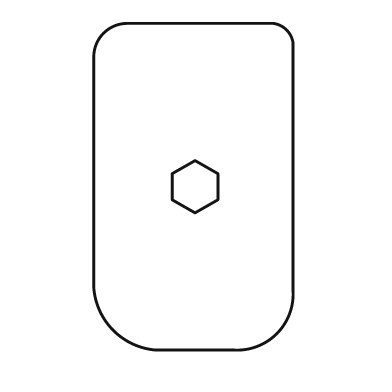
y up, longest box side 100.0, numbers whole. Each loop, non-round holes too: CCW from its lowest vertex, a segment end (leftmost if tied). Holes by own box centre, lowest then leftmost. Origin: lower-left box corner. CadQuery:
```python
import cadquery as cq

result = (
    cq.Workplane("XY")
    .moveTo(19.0, 0.0)
    .lineTo(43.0, 0.0)
    .threePointArc((56.0, 5.0), (61.0, 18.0))
    .lineTo(61.0, 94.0)
    .threePointArc((59.0, 98.0), (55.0, 100.0))
    .lineTo(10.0, 100.0)
    .threePointArc((3.0, 97.0), (0.0, 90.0))
    .lineTo(0.0, 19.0)
    .threePointArc((6.0, 6.0), (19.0, 0.0))
    .close()
    .moveTo(31.0, 42.0)
    .lineTo(38.0, 46.0)
    .lineTo(38.0, 54.0)
    .lineTo(31.0, 58.0)
    .lineTo(24.0, 54.0)
    .lineTo(24.0, 46.0)
    .close()
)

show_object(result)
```